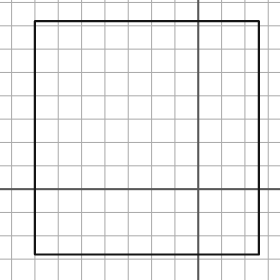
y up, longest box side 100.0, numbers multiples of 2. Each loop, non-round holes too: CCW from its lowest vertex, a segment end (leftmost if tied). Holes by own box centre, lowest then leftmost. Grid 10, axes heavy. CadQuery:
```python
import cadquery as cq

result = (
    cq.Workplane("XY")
    .moveTo(-70.0, -28.0)
    .lineTo(26.0, -28.0)
    .lineTo(26.0, 72.0)
    .lineTo(-70.0, 72.0)
    .close()
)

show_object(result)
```